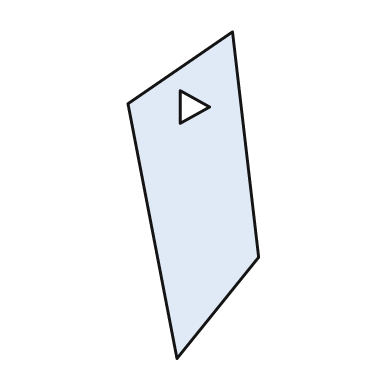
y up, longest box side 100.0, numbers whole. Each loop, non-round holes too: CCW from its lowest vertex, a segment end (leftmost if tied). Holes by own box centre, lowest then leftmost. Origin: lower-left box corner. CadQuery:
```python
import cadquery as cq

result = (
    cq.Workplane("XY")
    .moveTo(15.0, 0.0)
    .lineTo(40.0, 31.0)
    .lineTo(32.0, 100.0)
    .lineTo(0.0, 78.0)
    .close()
    .moveTo(16.0, 72.0)
    .lineTo(25.0, 77.0)
    .lineTo(16.0, 82.0)
    .close()
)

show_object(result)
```